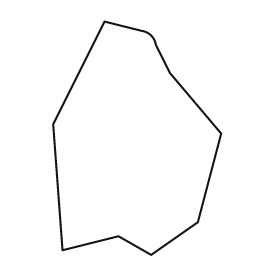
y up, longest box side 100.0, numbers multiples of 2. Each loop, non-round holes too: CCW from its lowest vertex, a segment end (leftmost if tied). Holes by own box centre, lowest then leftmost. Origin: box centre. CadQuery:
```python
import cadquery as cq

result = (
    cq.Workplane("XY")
    .moveTo(6.0, -50.0)
    .lineTo(26.0, -36.0)
    .lineTo(36.0, 2.0)
    .lineTo(14.0, 28.0)
    .lineTo(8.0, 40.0)
    .threePointArc((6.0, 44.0), (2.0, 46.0))
    .lineTo(-14.0, 50.0)
    .lineTo(-36.0, 6.0)
    .lineTo(-32.0, -48.0)
    .lineTo(-8.0, -42.0)
    .close()
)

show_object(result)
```